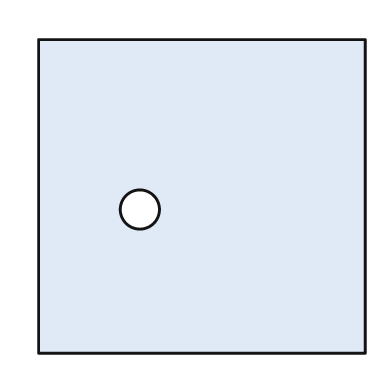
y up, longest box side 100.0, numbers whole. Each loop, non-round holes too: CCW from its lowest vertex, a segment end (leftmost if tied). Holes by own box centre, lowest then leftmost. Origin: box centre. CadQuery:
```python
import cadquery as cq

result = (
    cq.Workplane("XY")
    .moveTo(-50.0, -48.0)
    .lineTo(50.0, -48.0)
    .lineTo(50.0, 48.0)
    .lineTo(-50.0, 48.0)
    .close()
    .moveTo(-19.0, -4.0)
    .circle(6.0)
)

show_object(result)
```